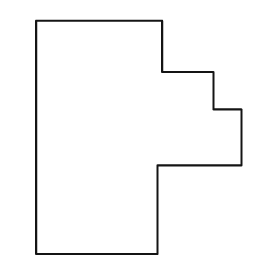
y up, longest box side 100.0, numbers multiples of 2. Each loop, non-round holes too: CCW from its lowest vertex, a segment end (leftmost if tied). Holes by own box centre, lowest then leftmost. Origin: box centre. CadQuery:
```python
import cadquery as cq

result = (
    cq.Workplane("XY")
    .moveTo(-44.0, -50.0)
    .lineTo(8.0, -50.0)
    .lineTo(8.0, -12.0)
    .lineTo(44.0, -12.0)
    .lineTo(44.0, 12.0)
    .lineTo(32.0, 12.0)
    .lineTo(32.0, 28.0)
    .lineTo(10.0, 28.0)
    .lineTo(10.0, 50.0)
    .lineTo(-44.0, 50.0)
    .close()
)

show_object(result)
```